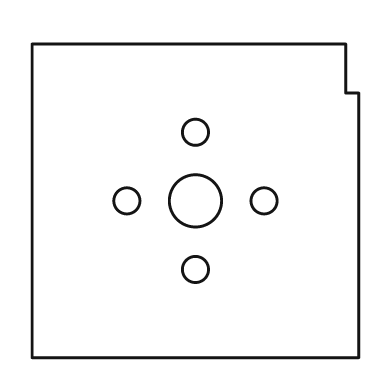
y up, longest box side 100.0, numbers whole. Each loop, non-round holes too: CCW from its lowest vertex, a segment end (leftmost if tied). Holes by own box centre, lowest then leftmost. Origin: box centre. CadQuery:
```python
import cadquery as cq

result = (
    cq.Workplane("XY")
    .moveTo(-50.0, -48.0)
    .lineTo(50.0, -48.0)
    .lineTo(50.0, 33.0)
    .lineTo(46.0, 33.0)
    .lineTo(46.0, 48.0)
    .lineTo(-50.0, 48.0)
    .close()
    .moveTo(0.0, -21.0)
    .circle(4.0)
    .moveTo(-21.0, 0.0)
    .circle(4.0)
    .moveTo(0.0, 0.0)
    .circle(8.0)
    .moveTo(21.0, 0.0)
    .circle(4.0)
    .moveTo(0.0, 21.0)
    .circle(4.0)
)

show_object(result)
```